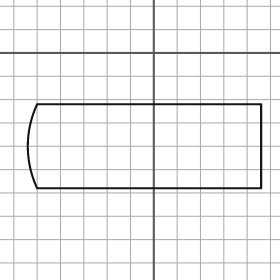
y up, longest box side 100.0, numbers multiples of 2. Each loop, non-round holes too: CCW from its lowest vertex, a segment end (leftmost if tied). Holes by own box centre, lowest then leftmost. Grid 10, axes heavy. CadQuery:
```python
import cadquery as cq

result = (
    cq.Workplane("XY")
    .moveTo(-50.0, -58.0)
    .lineTo(46.0, -58.0)
    .lineTo(46.0, -22.0)
    .lineTo(-50.0, -22.0)
    .threePointArc((-54.0, -40.0), (-50.0, -58.0))
    .close()
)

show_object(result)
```